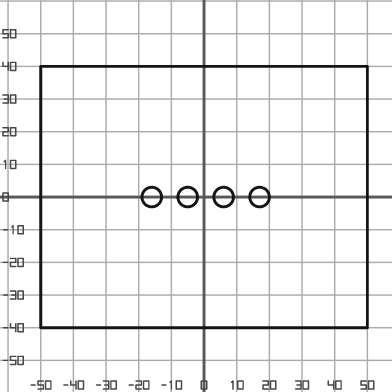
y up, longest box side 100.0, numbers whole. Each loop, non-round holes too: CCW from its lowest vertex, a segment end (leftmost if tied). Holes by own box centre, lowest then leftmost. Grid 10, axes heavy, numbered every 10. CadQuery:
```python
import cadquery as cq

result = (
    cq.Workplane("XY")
    .moveTo(-50.0, -40.0)
    .lineTo(50.0, -40.0)
    .lineTo(50.0, 40.0)
    .lineTo(-50.0, 40.0)
    .close()
    .moveTo(-16.0, 0.0)
    .circle(3.0)
    .moveTo(-5.0, 0.0)
    .circle(3.0)
    .moveTo(6.0, 0.0)
    .circle(3.0)
    .moveTo(17.0, 0.0)
    .circle(3.0)
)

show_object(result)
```